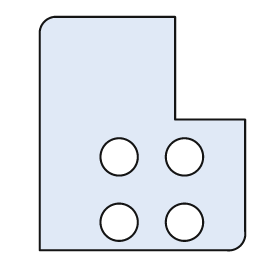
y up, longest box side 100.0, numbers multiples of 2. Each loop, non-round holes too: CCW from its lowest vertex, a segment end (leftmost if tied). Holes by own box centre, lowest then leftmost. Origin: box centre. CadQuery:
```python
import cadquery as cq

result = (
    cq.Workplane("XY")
    .moveTo(-44.0, -50.0)
    .lineTo(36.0, -50.0)
    .threePointArc((42.0, -48.0), (44.0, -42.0))
    .lineTo(44.0, 6.0)
    .lineTo(14.0, 6.0)
    .lineTo(14.0, 50.0)
    .lineTo(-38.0, 50.0)
    .threePointArc((-42.0, 48.0), (-44.0, 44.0))
    .close()
    .moveTo(-10.0, -38.0)
    .circle(8.0)
    .moveTo(18.0, -38.0)
    .circle(8.0)
    .moveTo(-10.0, -10.0)
    .circle(8.0)
    .moveTo(18.0, -10.0)
    .circle(8.0)
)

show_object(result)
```